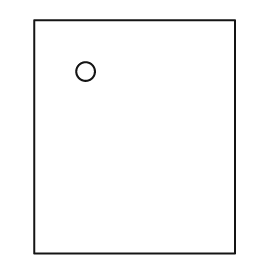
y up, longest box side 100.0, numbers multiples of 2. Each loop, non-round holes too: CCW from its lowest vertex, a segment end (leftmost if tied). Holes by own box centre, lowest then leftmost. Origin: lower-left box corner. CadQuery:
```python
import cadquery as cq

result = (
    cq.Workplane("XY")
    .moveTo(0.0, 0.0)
    .lineTo(86.0, 0.0)
    .lineTo(86.0, 100.0)
    .lineTo(0.0, 100.0)
    .close()
    .moveTo(22.0, 78.0)
    .circle(4.0)
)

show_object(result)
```